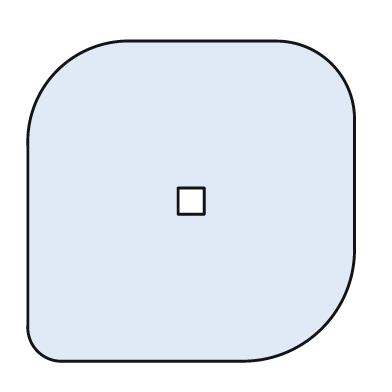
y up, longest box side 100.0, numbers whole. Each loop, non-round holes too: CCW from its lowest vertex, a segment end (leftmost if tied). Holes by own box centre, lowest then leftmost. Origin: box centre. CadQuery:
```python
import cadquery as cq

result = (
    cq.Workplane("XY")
    .moveTo(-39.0, -49.0)
    .lineTo(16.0, -49.0)
    .threePointArc((40.0, -39.0), (50.0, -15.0))
    .lineTo(50.0, 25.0)
    .threePointArc((43.0, 42.0), (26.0, 49.0))
    .lineTo(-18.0, 49.0)
    .threePointArc((-41.0, 40.0), (-50.0, 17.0))
    .lineTo(-50.0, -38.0)
    .threePointArc((-47.0, -46.0), (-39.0, -49.0))
    .close()
    .moveTo(-4.0, -4.0)
    .lineTo(4.0, -4.0)
    .lineTo(4.0, 4.0)
    .lineTo(-4.0, 4.0)
    .close()
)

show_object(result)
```